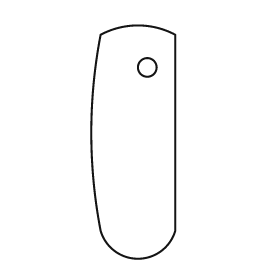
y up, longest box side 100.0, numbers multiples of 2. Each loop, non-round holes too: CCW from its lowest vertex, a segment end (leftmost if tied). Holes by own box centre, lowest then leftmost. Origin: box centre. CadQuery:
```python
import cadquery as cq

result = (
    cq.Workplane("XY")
    .moveTo(-14.0, -38.0)
    .threePointArc((2.0, -50.0), (18.0, -38.0))
    .lineTo(18.0, 46.0)
    .threePointArc((2.0, 50.0), (-14.0, 46.0))
    .threePointArc((-18.0, 4.0), (-14.0, -38.0))
    .close()
    .moveTo(6.0, 32.0)
    .circle(4.0)
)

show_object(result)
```